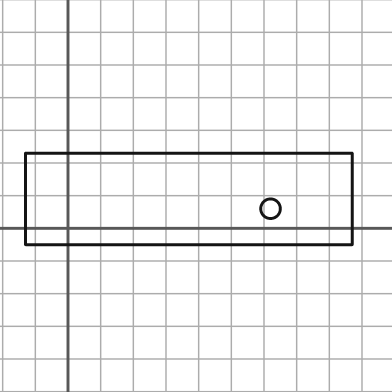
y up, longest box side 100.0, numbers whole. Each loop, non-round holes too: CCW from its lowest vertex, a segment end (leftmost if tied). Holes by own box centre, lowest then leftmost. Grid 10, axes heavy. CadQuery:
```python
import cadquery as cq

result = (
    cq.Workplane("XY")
    .moveTo(-13.0, -5.0)
    .lineTo(87.0, -5.0)
    .lineTo(87.0, 23.0)
    .lineTo(-13.0, 23.0)
    .close()
    .moveTo(62.0, 6.0)
    .circle(3.0)
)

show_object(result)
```